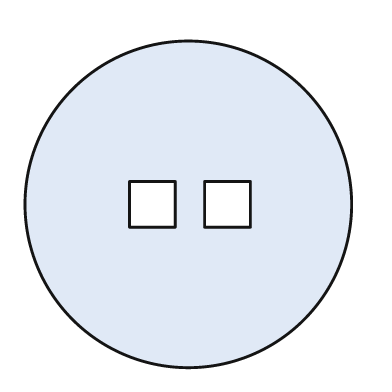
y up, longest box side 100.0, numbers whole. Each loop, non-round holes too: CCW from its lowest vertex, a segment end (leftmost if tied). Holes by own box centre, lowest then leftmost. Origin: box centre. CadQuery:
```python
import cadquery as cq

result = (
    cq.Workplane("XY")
    .moveTo(0.0, 0.0)
    .circle(50.0)
    .moveTo(-18.0, -7.0)
    .lineTo(-4.0, -7.0)
    .lineTo(-4.0, 7.0)
    .lineTo(-18.0, 7.0)
    .close()
    .moveTo(5.0, -7.0)
    .lineTo(19.0, -7.0)
    .lineTo(19.0, 7.0)
    .lineTo(5.0, 7.0)
    .close()
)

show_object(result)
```